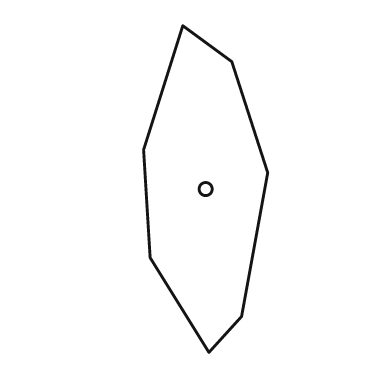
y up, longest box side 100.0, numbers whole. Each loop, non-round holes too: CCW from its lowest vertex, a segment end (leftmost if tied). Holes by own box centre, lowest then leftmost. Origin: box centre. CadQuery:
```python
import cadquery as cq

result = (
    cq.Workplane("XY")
    .moveTo(1.0, -50.0)
    .lineTo(11.0, -39.0)
    .lineTo(19.0, 5.0)
    .lineTo(8.0, 39.0)
    .lineTo(-7.0, 50.0)
    .lineTo(-19.0, 12.0)
    .lineTo(-17.0, -21.0)
    .close()
    .moveTo(0.0, 0.0)
    .circle(2.0)
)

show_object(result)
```